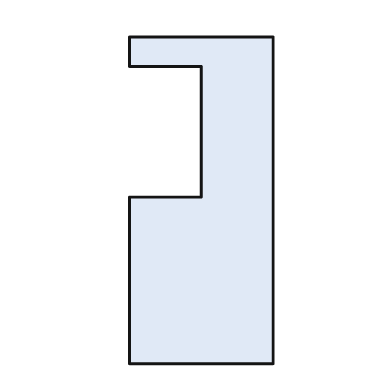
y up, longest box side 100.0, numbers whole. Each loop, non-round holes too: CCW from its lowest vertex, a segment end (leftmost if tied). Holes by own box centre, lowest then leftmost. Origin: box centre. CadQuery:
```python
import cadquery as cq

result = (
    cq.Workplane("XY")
    .moveTo(-22.0, -50.0)
    .lineTo(22.0, -50.0)
    .lineTo(22.0, 50.0)
    .lineTo(-22.0, 50.0)
    .lineTo(-22.0, 41.0)
    .lineTo(0.0, 41.0)
    .lineTo(0.0, 1.0)
    .lineTo(-22.0, 1.0)
    .close()
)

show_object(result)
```